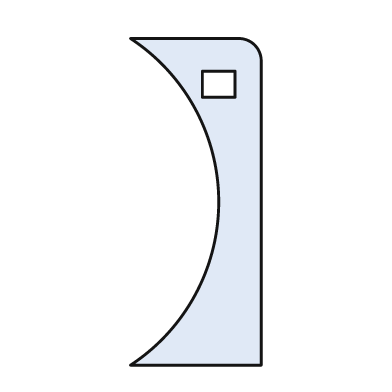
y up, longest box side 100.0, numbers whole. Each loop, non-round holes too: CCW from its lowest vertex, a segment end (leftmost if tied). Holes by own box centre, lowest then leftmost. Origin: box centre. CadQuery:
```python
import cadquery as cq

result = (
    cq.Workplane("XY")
    .moveTo(-20.0, -50.0)
    .lineTo(20.0, -50.0)
    .lineTo(20.0, 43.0)
    .threePointArc((18.0, 48.0), (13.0, 50.0))
    .lineTo(-20.0, 50.0)
    .threePointArc((7.0, 0.0), (-20.0, -50.0))
    .close()
    .moveTo(2.0, 32.0)
    .lineTo(12.0, 32.0)
    .lineTo(12.0, 40.0)
    .lineTo(2.0, 40.0)
    .close()
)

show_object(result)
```